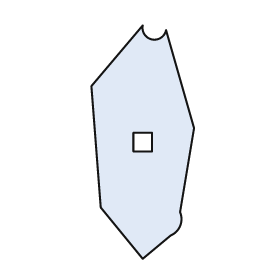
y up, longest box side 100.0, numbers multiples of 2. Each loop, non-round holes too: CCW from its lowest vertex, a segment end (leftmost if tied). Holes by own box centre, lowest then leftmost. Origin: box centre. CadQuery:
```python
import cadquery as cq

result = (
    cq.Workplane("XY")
    .moveTo(0.0, -50.0)
    .lineTo(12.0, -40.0)
    .threePointArc((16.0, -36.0), (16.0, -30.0))
    .lineTo(22.0, 6.0)
    .lineTo(10.0, 48.0)
    .threePointArc((4.0, 44.0), (0.0, 50.0))
    .lineTo(-22.0, 24.0)
    .lineTo(-18.0, -28.0)
    .close()
    .moveTo(-4.0, -4.0)
    .lineTo(4.0, -4.0)
    .lineTo(4.0, 4.0)
    .lineTo(-4.0, 4.0)
    .close()
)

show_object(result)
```